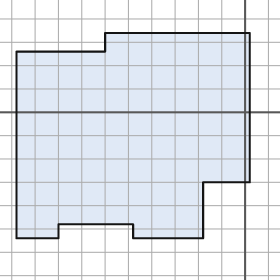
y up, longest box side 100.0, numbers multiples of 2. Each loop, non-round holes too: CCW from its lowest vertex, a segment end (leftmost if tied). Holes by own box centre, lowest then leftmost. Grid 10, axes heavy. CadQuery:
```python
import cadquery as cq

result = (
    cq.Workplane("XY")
    .moveTo(-98.0, -54.0)
    .lineTo(-80.0, -54.0)
    .lineTo(-80.0, -48.0)
    .lineTo(-48.0, -48.0)
    .lineTo(-48.0, -54.0)
    .lineTo(-18.0, -54.0)
    .lineTo(-18.0, -30.0)
    .lineTo(2.0, -30.0)
    .lineTo(2.0, 34.0)
    .lineTo(-60.0, 34.0)
    .lineTo(-60.0, 26.0)
    .lineTo(-98.0, 26.0)
    .close()
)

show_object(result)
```